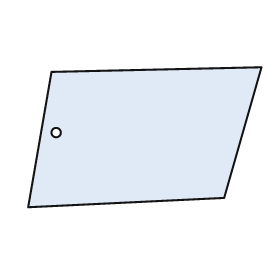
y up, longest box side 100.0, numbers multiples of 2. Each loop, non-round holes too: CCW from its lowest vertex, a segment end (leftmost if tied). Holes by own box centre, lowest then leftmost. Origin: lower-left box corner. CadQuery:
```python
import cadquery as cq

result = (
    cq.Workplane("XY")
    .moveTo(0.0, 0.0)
    .lineTo(84.0, 4.0)
    .lineTo(100.0, 60.0)
    .lineTo(10.0, 58.0)
    .close()
    .moveTo(12.0, 32.0)
    .circle(2.0)
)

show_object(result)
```